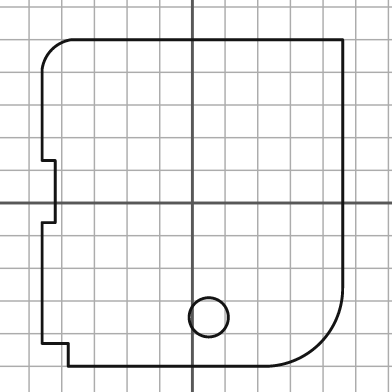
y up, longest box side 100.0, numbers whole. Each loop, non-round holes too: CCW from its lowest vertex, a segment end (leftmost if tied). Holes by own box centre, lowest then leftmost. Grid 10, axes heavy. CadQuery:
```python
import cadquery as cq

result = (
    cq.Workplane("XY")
    .moveTo(-38.0, -50.0)
    .lineTo(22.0, -50.0)
    .threePointArc((39.0, -43.0), (46.0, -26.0))
    .lineTo(46.0, 50.0)
    .lineTo(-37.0, 50.0)
    .threePointArc((-43.0, 47.0), (-46.0, 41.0))
    .lineTo(-46.0, 13.0)
    .lineTo(-42.0, 13.0)
    .lineTo(-42.0, -6.0)
    .lineTo(-46.0, -6.0)
    .lineTo(-46.0, -43.0)
    .lineTo(-38.0, -43.0)
    .close()
    .moveTo(5.0, -35.0)
    .circle(6.0)
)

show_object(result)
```